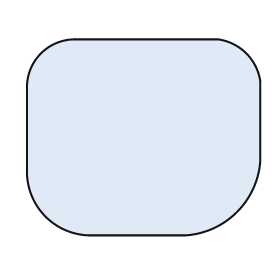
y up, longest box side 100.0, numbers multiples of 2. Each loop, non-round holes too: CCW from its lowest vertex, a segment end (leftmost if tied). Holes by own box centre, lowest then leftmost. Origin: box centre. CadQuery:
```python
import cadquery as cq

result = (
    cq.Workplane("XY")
    .moveTo(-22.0, -42.0)
    .lineTo(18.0, -42.0)
    .threePointArc((40.0, -32.0), (50.0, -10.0))
    .lineTo(50.0, 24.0)
    .threePointArc((44.0, 36.0), (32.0, 42.0))
    .lineTo(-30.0, 42.0)
    .threePointArc((-44.0, 36.0), (-50.0, 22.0))
    .lineTo(-50.0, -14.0)
    .threePointArc((-42.0, -34.0), (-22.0, -42.0))
    .close()
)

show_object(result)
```